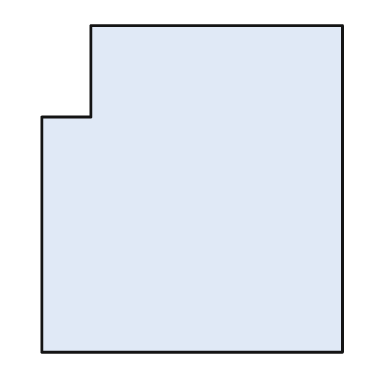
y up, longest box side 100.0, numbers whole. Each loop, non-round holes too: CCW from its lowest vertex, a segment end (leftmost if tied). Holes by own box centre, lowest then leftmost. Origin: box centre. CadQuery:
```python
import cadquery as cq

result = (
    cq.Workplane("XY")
    .moveTo(-46.0, -50.0)
    .lineTo(46.0, -50.0)
    .lineTo(46.0, 50.0)
    .lineTo(-31.0, 50.0)
    .lineTo(-31.0, 22.0)
    .lineTo(-46.0, 22.0)
    .close()
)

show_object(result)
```